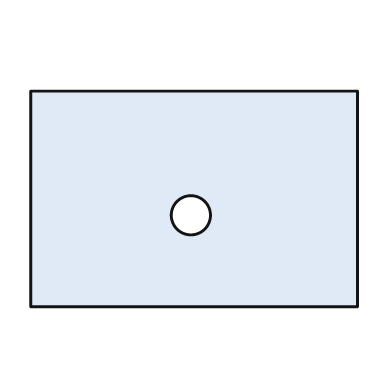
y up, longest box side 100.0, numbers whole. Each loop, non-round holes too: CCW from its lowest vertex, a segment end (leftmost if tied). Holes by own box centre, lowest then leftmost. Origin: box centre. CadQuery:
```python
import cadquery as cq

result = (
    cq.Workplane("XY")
    .moveTo(-50.0, -33.0)
    .lineTo(50.0, -33.0)
    .lineTo(50.0, 33.0)
    .lineTo(-50.0, 33.0)
    .close()
    .moveTo(-1.0, -5.0)
    .circle(6.0)
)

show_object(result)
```